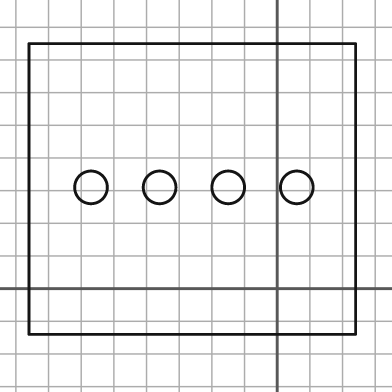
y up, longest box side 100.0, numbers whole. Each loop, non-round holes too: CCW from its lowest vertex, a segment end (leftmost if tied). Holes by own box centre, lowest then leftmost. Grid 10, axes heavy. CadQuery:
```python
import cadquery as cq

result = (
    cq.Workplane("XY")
    .moveTo(-76.0, -14.0)
    .lineTo(24.0, -14.0)
    .lineTo(24.0, 75.0)
    .lineTo(-76.0, 75.0)
    .close()
    .moveTo(-57.0, 31.0)
    .circle(5.0)
    .moveTo(-36.0, 31.0)
    .circle(5.0)
    .moveTo(-15.0, 31.0)
    .circle(5.0)
    .moveTo(6.0, 31.0)
    .circle(5.0)
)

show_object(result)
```